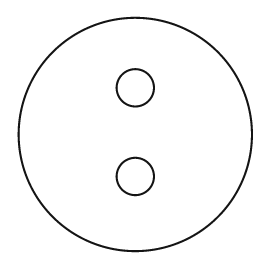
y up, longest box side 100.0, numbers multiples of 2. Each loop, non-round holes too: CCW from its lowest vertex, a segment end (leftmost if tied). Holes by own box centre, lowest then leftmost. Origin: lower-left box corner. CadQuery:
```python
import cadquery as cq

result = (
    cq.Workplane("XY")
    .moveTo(50.0, 50.0)
    .circle(50.0)
    .moveTo(50.0, 32.0)
    .circle(8.0)
    .moveTo(50.0, 70.0)
    .circle(8.0)
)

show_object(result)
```